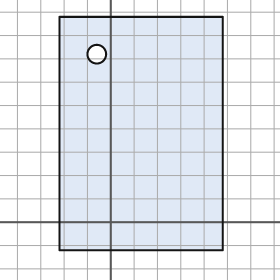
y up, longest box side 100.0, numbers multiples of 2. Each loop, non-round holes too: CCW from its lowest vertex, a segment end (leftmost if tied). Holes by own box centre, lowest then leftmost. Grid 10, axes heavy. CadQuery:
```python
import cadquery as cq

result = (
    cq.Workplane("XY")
    .moveTo(-22.0, -12.0)
    .lineTo(48.0, -12.0)
    .lineTo(48.0, 88.0)
    .lineTo(-22.0, 88.0)
    .close()
    .moveTo(-6.0, 72.0)
    .circle(4.0)
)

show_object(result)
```